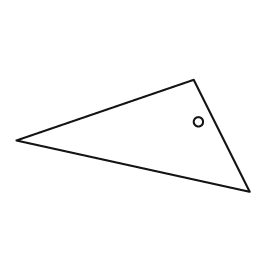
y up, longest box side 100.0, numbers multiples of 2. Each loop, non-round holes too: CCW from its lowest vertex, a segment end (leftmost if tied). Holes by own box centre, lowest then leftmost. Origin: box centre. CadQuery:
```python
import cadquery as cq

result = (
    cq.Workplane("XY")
    .moveTo(50.0, -24.0)
    .lineTo(26.0, 24.0)
    .lineTo(-50.0, -2.0)
    .close()
    .moveTo(28.0, 6.0)
    .circle(2.0)
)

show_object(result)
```